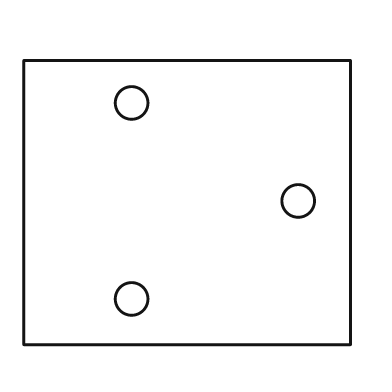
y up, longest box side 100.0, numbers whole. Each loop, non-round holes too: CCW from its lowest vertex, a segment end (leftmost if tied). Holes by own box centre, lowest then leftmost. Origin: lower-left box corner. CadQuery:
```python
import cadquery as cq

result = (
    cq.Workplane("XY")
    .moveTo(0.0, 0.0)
    .lineTo(100.0, 0.0)
    .lineTo(100.0, 87.0)
    .lineTo(0.0, 87.0)
    .close()
    .moveTo(33.0, 14.0)
    .circle(5.0)
    .moveTo(84.0, 44.0)
    .circle(5.0)
    .moveTo(33.0, 74.0)
    .circle(5.0)
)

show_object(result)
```